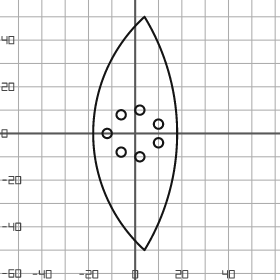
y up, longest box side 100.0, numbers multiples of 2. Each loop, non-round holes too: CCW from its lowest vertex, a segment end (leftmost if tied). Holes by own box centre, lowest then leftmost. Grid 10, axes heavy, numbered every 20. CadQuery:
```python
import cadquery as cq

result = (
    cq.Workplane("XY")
    .moveTo(4.0, -50.0)
    .threePointArc((18.0, 0.0), (4.0, 50.0))
    .threePointArc((-18.0, 0.0), (4.0, -50.0))
    .close()
    .moveTo(2.0, -10.0)
    .circle(2.0)
    .moveTo(-6.0, -8.0)
    .circle(2.0)
    .moveTo(10.0, -4.0)
    .circle(2.0)
    .moveTo(-12.0, 0.0)
    .circle(2.0)
    .moveTo(10.0, 4.0)
    .circle(2.0)
    .moveTo(-6.0, 8.0)
    .circle(2.0)
    .moveTo(2.0, 10.0)
    .circle(2.0)
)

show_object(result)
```